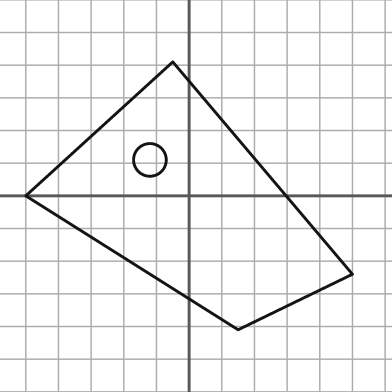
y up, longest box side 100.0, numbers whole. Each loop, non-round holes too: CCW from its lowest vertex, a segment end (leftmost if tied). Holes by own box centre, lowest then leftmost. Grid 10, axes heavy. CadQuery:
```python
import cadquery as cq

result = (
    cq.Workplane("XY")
    .moveTo(15.0, -41.0)
    .lineTo(50.0, -24.0)
    .lineTo(-5.0, 41.0)
    .lineTo(-50.0, 0.0)
    .close()
    .moveTo(-12.0, 11.0)
    .circle(5.0)
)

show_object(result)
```